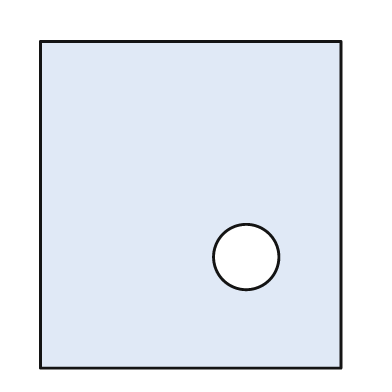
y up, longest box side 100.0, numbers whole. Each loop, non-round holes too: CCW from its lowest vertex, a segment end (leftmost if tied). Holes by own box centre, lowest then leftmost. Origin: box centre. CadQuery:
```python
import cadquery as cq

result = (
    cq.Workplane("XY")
    .moveTo(-46.0, -50.0)
    .lineTo(46.0, -50.0)
    .lineTo(46.0, 50.0)
    .lineTo(-46.0, 50.0)
    .close()
    .moveTo(17.0, -16.0)
    .circle(10.0)
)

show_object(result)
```